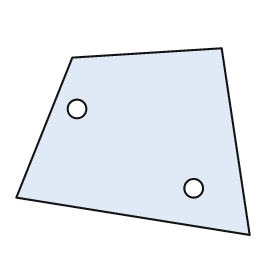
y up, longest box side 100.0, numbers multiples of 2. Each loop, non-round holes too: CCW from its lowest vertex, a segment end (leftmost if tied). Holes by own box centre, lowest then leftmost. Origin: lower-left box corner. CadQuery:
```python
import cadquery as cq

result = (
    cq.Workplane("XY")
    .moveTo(100.0, 0.0)
    .lineTo(88.0, 80.0)
    .lineTo(24.0, 76.0)
    .lineTo(0.0, 16.0)
    .close()
    .moveTo(76.0, 20.0)
    .circle(4.0)
    .moveTo(26.0, 54.0)
    .circle(4.0)
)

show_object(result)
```